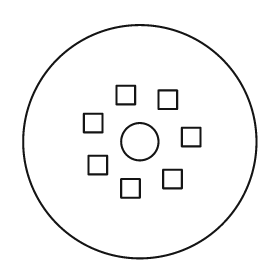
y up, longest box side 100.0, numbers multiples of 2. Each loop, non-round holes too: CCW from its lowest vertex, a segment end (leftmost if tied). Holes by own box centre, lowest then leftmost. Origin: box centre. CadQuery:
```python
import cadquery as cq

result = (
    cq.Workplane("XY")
    .moveTo(0.0, 0.0)
    .circle(50.0)
    .moveTo(-8.0, -24.0)
    .lineTo(0.0, -24.0)
    .lineTo(0.0, -16.0)
    .lineTo(-8.0, -16.0)
    .close()
    .moveTo(10.0, -20.0)
    .lineTo(18.0, -20.0)
    .lineTo(18.0, -12.0)
    .lineTo(10.0, -12.0)
    .close()
    .moveTo(-22.0, -14.0)
    .lineTo(-14.0, -14.0)
    .lineTo(-14.0, -6.0)
    .lineTo(-22.0, -6.0)
    .close()
    .moveTo(0.0, 0.0)
    .circle(8.0)
    .moveTo(18.0, -2.0)
    .lineTo(26.0, -2.0)
    .lineTo(26.0, 6.0)
    .lineTo(18.0, 6.0)
    .close()
    .moveTo(-24.0, 4.0)
    .lineTo(-16.0, 4.0)
    .lineTo(-16.0, 12.0)
    .lineTo(-24.0, 12.0)
    .close()
    .moveTo(8.0, 14.0)
    .lineTo(16.0, 14.0)
    .lineTo(16.0, 22.0)
    .lineTo(8.0, 22.0)
    .close()
    .moveTo(-10.0, 16.0)
    .lineTo(-2.0, 16.0)
    .lineTo(-2.0, 24.0)
    .lineTo(-10.0, 24.0)
    .close()
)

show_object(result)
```